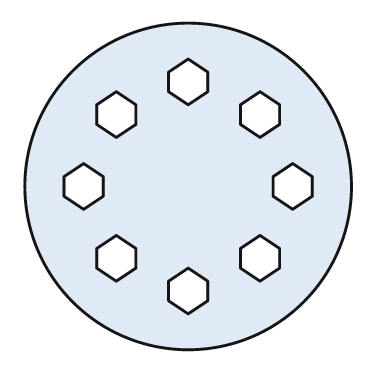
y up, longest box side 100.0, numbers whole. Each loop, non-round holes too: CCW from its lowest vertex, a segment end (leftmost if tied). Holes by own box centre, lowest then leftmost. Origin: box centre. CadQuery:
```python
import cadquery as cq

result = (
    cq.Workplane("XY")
    .moveTo(0.0, 0.0)
    .circle(50.0)
    .moveTo(0.0, -39.0)
    .lineTo(6.0, -35.0)
    .lineTo(6.0, -29.0)
    .lineTo(0.0, -25.0)
    .lineTo(-6.0, -29.0)
    .lineTo(-6.0, -35.0)
    .close()
    .moveTo(-22.0, -29.0)
    .lineTo(-16.0, -25.0)
    .lineTo(-16.0, -19.0)
    .lineTo(-22.0, -15.0)
    .lineTo(-28.0, -19.0)
    .lineTo(-28.0, -25.0)
    .close()
    .moveTo(22.0, -29.0)
    .lineTo(28.0, -25.0)
    .lineTo(28.0, -19.0)
    .lineTo(22.0, -15.0)
    .lineTo(16.0, -19.0)
    .lineTo(16.0, -25.0)
    .close()
    .moveTo(-32.0, -7.0)
    .lineTo(-26.0, -3.0)
    .lineTo(-26.0, 3.0)
    .lineTo(-32.0, 7.0)
    .lineTo(-38.0, 3.0)
    .lineTo(-38.0, -3.0)
    .close()
    .moveTo(32.0, -7.0)
    .lineTo(38.0, -3.0)
    .lineTo(38.0, 3.0)
    .lineTo(32.0, 7.0)
    .lineTo(26.0, 3.0)
    .lineTo(26.0, -3.0)
    .close()
    .moveTo(-22.0, 15.0)
    .lineTo(-16.0, 19.0)
    .lineTo(-16.0, 25.0)
    .lineTo(-22.0, 29.0)
    .lineTo(-28.0, 25.0)
    .lineTo(-28.0, 19.0)
    .close()
    .moveTo(22.0, 15.0)
    .lineTo(28.0, 19.0)
    .lineTo(28.0, 25.0)
    .lineTo(22.0, 29.0)
    .lineTo(16.0, 25.0)
    .lineTo(16.0, 19.0)
    .close()
    .moveTo(0.0, 25.0)
    .lineTo(6.0, 29.0)
    .lineTo(6.0, 35.0)
    .lineTo(0.0, 39.0)
    .lineTo(-6.0, 35.0)
    .lineTo(-6.0, 29.0)
    .close()
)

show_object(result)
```